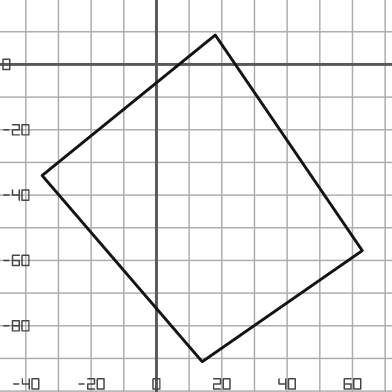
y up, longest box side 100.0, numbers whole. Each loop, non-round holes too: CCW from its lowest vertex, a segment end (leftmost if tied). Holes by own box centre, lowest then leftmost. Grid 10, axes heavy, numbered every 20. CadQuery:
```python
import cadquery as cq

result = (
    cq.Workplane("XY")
    .moveTo(14.0, -91.0)
    .lineTo(63.0, -57.0)
    .lineTo(18.0, 9.0)
    .lineTo(-35.0, -34.0)
    .close()
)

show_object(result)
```